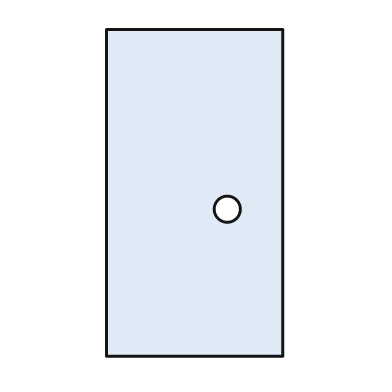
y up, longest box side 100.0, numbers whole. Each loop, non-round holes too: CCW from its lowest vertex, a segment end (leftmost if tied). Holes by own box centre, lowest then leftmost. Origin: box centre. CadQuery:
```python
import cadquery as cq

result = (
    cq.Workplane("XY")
    .moveTo(-27.0, -50.0)
    .lineTo(27.0, -50.0)
    .lineTo(27.0, 50.0)
    .lineTo(-27.0, 50.0)
    .close()
    .moveTo(10.0, -5.0)
    .circle(4.0)
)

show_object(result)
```